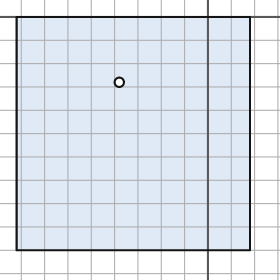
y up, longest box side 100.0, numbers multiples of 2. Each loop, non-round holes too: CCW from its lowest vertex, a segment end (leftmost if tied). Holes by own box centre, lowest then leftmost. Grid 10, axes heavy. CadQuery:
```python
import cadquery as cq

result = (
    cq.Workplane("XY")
    .moveTo(-82.0, -100.0)
    .lineTo(18.0, -100.0)
    .lineTo(18.0, 0.0)
    .lineTo(-82.0, 0.0)
    .close()
    .moveTo(-38.0, -28.0)
    .circle(2.0)
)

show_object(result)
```